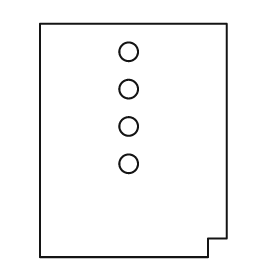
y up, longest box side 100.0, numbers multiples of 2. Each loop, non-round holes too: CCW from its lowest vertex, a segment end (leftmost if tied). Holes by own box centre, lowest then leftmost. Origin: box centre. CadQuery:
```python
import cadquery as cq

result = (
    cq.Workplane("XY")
    .moveTo(-40.0, -50.0)
    .lineTo(32.0, -50.0)
    .lineTo(32.0, -42.0)
    .lineTo(40.0, -42.0)
    .lineTo(40.0, 50.0)
    .lineTo(-40.0, 50.0)
    .close()
    .moveTo(-2.0, -10.0)
    .circle(4.0)
    .moveTo(-2.0, 6.0)
    .circle(4.0)
    .moveTo(-2.0, 22.0)
    .circle(4.0)
    .moveTo(-2.0, 38.0)
    .circle(4.0)
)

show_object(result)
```